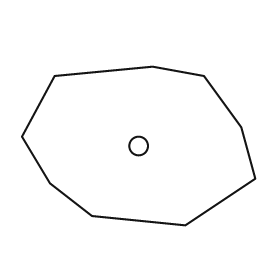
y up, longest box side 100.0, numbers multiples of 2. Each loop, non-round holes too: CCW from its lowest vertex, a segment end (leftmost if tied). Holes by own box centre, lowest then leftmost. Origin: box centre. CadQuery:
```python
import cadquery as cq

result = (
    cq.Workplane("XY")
    .moveTo(20.0, -34.0)
    .lineTo(50.0, -14.0)
    .lineTo(44.0, 8.0)
    .lineTo(28.0, 30.0)
    .lineTo(6.0, 34.0)
    .lineTo(-36.0, 30.0)
    .lineTo(-50.0, 4.0)
    .lineTo(-38.0, -16.0)
    .lineTo(-20.0, -30.0)
    .close()
    .moveTo(0.0, 0.0)
    .circle(4.0)
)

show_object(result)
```